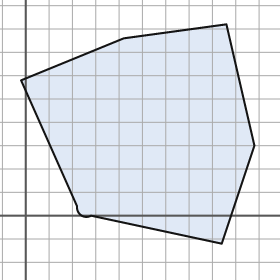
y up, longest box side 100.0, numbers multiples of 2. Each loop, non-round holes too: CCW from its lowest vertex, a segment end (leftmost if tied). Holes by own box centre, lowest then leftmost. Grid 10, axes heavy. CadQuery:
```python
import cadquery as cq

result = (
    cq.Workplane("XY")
    .moveTo(84.0, -12.0)
    .lineTo(98.0, 30.0)
    .lineTo(86.0, 82.0)
    .lineTo(42.0, 76.0)
    .lineTo(-2.0, 58.0)
    .lineTo(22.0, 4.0)
    .threePointArc((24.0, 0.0), (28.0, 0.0))
    .close()
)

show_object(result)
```